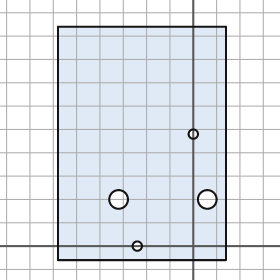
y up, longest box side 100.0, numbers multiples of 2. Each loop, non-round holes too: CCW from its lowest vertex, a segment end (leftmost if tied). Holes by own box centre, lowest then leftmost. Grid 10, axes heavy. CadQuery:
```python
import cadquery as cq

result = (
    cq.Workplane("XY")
    .moveTo(-58.0, -6.0)
    .lineTo(14.0, -6.0)
    .lineTo(14.0, 94.0)
    .lineTo(-58.0, 94.0)
    .close()
    .moveTo(-24.0, 0.0)
    .circle(2.0)
    .moveTo(-32.0, 20.0)
    .circle(4.0)
    .moveTo(6.0, 20.0)
    .circle(4.0)
    .moveTo(0.0, 48.0)
    .circle(2.0)
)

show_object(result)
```